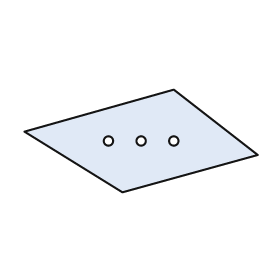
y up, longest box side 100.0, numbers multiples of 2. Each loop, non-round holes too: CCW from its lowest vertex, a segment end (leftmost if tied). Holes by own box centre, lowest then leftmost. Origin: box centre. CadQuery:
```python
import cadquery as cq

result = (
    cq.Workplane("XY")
    .moveTo(-8.0, -22.0)
    .lineTo(50.0, -6.0)
    .lineTo(14.0, 22.0)
    .lineTo(-50.0, 4.0)
    .close()
    .moveTo(-14.0, 0.0)
    .circle(2.0)
    .moveTo(0.0, 0.0)
    .circle(2.0)
    .moveTo(14.0, 0.0)
    .circle(2.0)
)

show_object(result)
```